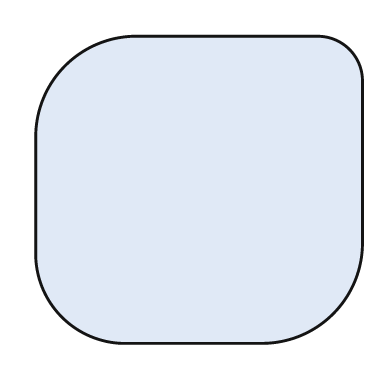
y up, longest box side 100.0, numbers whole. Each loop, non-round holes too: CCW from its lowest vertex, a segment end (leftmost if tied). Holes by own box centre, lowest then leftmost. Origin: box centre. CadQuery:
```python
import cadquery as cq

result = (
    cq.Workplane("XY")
    .moveTo(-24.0, -47.0)
    .lineTo(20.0, -47.0)
    .threePointArc((41.0, -38.0), (50.0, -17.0))
    .lineTo(50.0, 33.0)
    .threePointArc((46.0, 43.0), (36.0, 47.0))
    .lineTo(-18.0, 47.0)
    .threePointArc((-41.0, 38.0), (-50.0, 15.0))
    .lineTo(-50.0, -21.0)
    .threePointArc((-42.0, -39.0), (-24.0, -47.0))
    .close()
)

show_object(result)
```